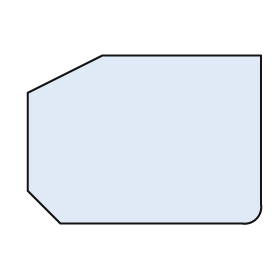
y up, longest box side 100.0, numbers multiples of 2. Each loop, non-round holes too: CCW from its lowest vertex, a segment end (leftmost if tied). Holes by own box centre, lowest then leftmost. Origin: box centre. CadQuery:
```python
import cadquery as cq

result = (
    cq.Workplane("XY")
    .moveTo(-36.0, -36.0)
    .lineTo(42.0, -36.0)
    .threePointArc((48.0, -34.0), (50.0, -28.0))
    .lineTo(50.0, 36.0)
    .lineTo(-18.0, 36.0)
    .lineTo(-50.0, 20.0)
    .lineTo(-50.0, -22.0)
    .close()
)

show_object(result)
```